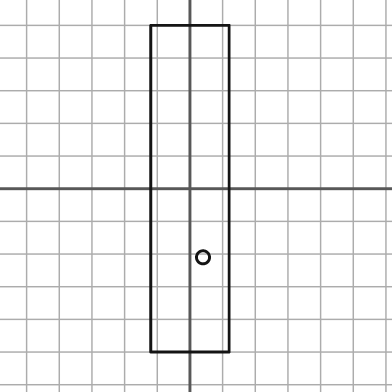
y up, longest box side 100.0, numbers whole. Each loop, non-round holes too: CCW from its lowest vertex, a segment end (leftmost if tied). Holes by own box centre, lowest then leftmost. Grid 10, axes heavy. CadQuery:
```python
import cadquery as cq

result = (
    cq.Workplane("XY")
    .moveTo(-12.0, -50.0)
    .lineTo(12.0, -50.0)
    .lineTo(12.0, 50.0)
    .lineTo(-12.0, 50.0)
    .close()
    .moveTo(4.0, -21.0)
    .circle(2.0)
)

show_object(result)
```